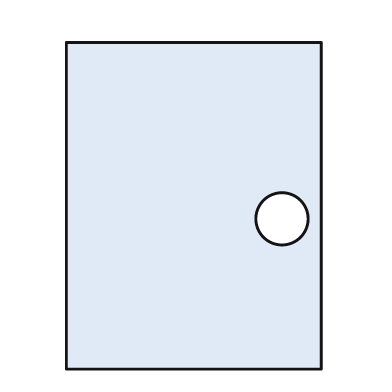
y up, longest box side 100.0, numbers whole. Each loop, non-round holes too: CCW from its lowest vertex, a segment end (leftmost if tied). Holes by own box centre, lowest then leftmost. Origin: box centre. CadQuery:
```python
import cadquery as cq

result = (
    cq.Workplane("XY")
    .moveTo(-39.0, -50.0)
    .lineTo(39.0, -50.0)
    .lineTo(39.0, 50.0)
    .lineTo(-39.0, 50.0)
    .close()
    .moveTo(27.0, -4.0)
    .circle(8.0)
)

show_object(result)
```